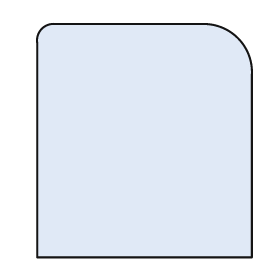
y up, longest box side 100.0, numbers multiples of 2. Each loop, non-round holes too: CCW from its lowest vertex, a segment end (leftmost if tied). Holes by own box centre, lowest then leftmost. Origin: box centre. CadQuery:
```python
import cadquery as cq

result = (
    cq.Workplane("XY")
    .moveTo(-46.0, -50.0)
    .lineTo(46.0, -50.0)
    .lineTo(46.0, 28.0)
    .threePointArc((40.0, 44.0), (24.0, 50.0))
    .lineTo(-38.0, 50.0)
    .threePointArc((-44.0, 48.0), (-46.0, 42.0))
    .close()
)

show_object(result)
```